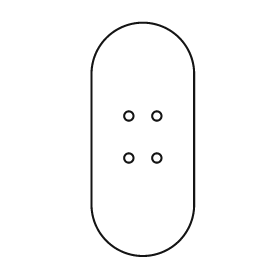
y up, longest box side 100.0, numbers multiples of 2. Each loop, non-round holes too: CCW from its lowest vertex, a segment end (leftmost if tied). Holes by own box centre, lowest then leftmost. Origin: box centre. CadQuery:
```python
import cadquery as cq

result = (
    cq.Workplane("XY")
    .moveTo(-22.0, -28.0)
    .threePointArc((0.0, -50.0), (22.0, -28.0))
    .lineTo(22.0, 28.0)
    .threePointArc((0.0, 50.0), (-22.0, 28.0))
    .close()
    .moveTo(-6.0, -8.0)
    .circle(2.0)
    .moveTo(6.0, -8.0)
    .circle(2.0)
    .moveTo(-6.0, 10.0)
    .circle(2.0)
    .moveTo(6.0, 10.0)
    .circle(2.0)
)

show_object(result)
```